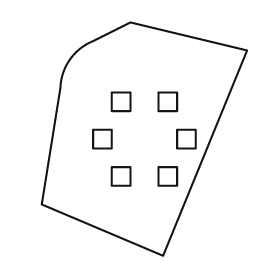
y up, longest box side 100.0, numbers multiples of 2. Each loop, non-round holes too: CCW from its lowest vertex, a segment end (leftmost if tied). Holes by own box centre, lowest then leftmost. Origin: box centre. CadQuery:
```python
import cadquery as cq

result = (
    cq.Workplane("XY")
    .moveTo(8.0, -50.0)
    .lineTo(44.0, 38.0)
    .lineTo(-6.0, 50.0)
    .lineTo(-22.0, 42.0)
    .threePointArc((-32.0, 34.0), (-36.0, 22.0))
    .lineTo(-44.0, -28.0)
    .close()
    .moveTo(-14.0, -20.0)
    .lineTo(-6.0, -20.0)
    .lineTo(-6.0, -12.0)
    .lineTo(-14.0, -12.0)
    .close()
    .moveTo(6.0, -20.0)
    .lineTo(14.0, -20.0)
    .lineTo(14.0, -12.0)
    .lineTo(6.0, -12.0)
    .close()
    .moveTo(-22.0, -4.0)
    .lineTo(-14.0, -4.0)
    .lineTo(-14.0, 4.0)
    .lineTo(-22.0, 4.0)
    .close()
    .moveTo(14.0, -4.0)
    .lineTo(22.0, -4.0)
    .lineTo(22.0, 4.0)
    .lineTo(14.0, 4.0)
    .close()
    .moveTo(-14.0, 12.0)
    .lineTo(-6.0, 12.0)
    .lineTo(-6.0, 20.0)
    .lineTo(-14.0, 20.0)
    .close()
    .moveTo(6.0, 12.0)
    .lineTo(14.0, 12.0)
    .lineTo(14.0, 20.0)
    .lineTo(6.0, 20.0)
    .close()
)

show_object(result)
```